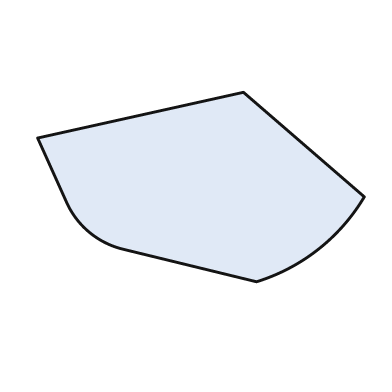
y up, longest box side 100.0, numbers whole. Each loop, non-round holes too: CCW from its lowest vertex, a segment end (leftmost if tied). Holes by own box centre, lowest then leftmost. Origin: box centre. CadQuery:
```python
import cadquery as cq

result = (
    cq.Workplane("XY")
    .moveTo(17.0, -29.0)
    .threePointArc((36.0, -19.0), (50.0, -3.0))
    .lineTo(13.0, 29.0)
    .lineTo(-50.0, 15.0)
    .lineTo(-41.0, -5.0)
    .threePointArc((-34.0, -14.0), (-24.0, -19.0))
    .close()
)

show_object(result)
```